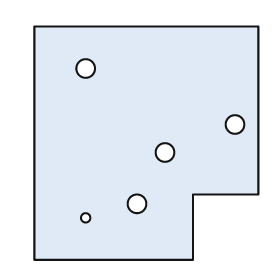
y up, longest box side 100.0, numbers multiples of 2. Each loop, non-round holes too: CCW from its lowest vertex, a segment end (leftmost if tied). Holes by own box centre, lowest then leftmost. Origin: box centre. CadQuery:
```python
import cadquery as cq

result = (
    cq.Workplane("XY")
    .moveTo(-48.0, -50.0)
    .lineTo(20.0, -50.0)
    .lineTo(20.0, -22.0)
    .lineTo(48.0, -22.0)
    .lineTo(48.0, 50.0)
    .lineTo(-48.0, 50.0)
    .close()
    .moveTo(-26.0, -32.0)
    .circle(2.0)
    .moveTo(-4.0, -26.0)
    .circle(4.0)
    .moveTo(8.0, -4.0)
    .circle(4.0)
    .moveTo(38.0, 8.0)
    .circle(4.0)
    .moveTo(-26.0, 32.0)
    .circle(4.0)
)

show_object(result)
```